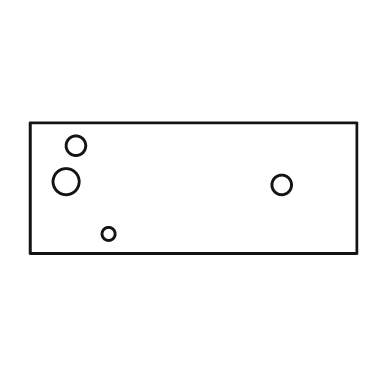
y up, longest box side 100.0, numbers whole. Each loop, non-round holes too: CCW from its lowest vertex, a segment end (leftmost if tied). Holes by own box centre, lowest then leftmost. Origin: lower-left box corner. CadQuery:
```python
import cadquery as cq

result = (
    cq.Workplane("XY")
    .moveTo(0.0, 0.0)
    .lineTo(100.0, 0.0)
    .lineTo(100.0, 40.0)
    .lineTo(0.0, 40.0)
    .close()
    .moveTo(24.0, 6.0)
    .circle(2.0)
    .moveTo(77.0, 21.0)
    .circle(3.0)
    .moveTo(11.0, 22.0)
    .circle(4.0)
    .moveTo(14.0, 33.0)
    .circle(3.0)
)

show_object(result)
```